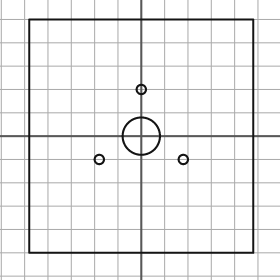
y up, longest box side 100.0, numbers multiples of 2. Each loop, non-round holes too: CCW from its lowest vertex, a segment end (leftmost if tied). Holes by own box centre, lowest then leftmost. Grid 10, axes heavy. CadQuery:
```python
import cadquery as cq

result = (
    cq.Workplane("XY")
    .moveTo(-48.0, -50.0)
    .lineTo(48.0, -50.0)
    .lineTo(48.0, 50.0)
    .lineTo(-48.0, 50.0)
    .close()
    .moveTo(-18.0, -10.0)
    .circle(2.0)
    .moveTo(18.0, -10.0)
    .circle(2.0)
    .moveTo(0.0, 0.0)
    .circle(8.0)
    .moveTo(0.0, 20.0)
    .circle(2.0)
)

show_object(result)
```